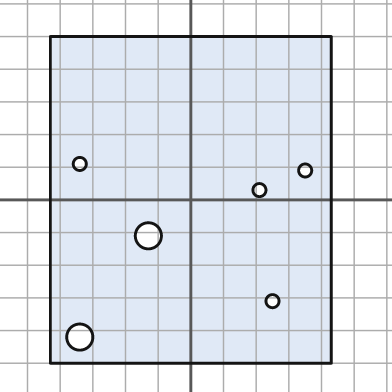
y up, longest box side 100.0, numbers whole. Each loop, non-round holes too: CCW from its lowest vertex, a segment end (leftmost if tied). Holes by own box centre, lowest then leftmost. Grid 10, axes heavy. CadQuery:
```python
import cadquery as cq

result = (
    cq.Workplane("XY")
    .moveTo(-43.0, -50.0)
    .lineTo(43.0, -50.0)
    .lineTo(43.0, 50.0)
    .lineTo(-43.0, 50.0)
    .close()
    .moveTo(-34.0, -42.0)
    .circle(4.0)
    .moveTo(25.0, -31.0)
    .circle(2.0)
    .moveTo(-13.0, -11.0)
    .circle(4.0)
    .moveTo(21.0, 3.0)
    .circle(2.0)
    .moveTo(35.0, 9.0)
    .circle(2.0)
    .moveTo(-34.0, 11.0)
    .circle(2.0)
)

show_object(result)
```